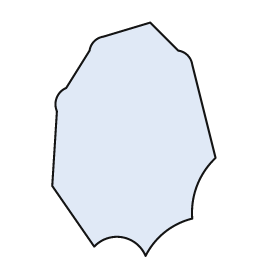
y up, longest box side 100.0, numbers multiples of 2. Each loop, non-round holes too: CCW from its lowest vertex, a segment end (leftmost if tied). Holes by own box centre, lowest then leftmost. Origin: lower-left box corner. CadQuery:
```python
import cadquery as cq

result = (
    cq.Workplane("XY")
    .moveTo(40.0, 0.0)
    .threePointArc((48.0, 10.0), (60.0, 16.0))
    .threePointArc((62.0, 30.0), (70.0, 42.0))
    .lineTo(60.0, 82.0)
    .threePointArc((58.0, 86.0), (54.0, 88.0))
    .lineTo(42.0, 100.0)
    .lineTo(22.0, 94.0)
    .threePointArc((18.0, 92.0), (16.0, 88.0))
    .lineTo(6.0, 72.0)
    .threePointArc((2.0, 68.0), (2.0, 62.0))
    .lineTo(0.0, 30.0)
    .lineTo(18.0, 4.0)
    .threePointArc((30.0, 8.0), (40.0, 0.0))
    .close()
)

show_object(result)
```